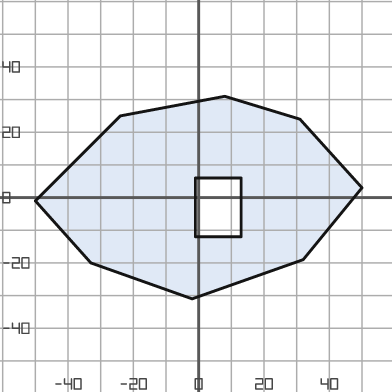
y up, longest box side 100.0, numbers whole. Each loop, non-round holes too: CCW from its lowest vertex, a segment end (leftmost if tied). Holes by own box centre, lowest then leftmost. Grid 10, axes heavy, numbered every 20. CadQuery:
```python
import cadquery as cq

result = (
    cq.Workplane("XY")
    .moveTo(-2.0, -31.0)
    .lineTo(32.0, -19.0)
    .lineTo(50.0, 3.0)
    .lineTo(31.0, 24.0)
    .lineTo(8.0, 31.0)
    .lineTo(-24.0, 25.0)
    .lineTo(-50.0, -1.0)
    .lineTo(-33.0, -20.0)
    .close()
    .moveTo(-1.0, -12.0)
    .lineTo(13.0, -12.0)
    .lineTo(13.0, 6.0)
    .lineTo(-1.0, 6.0)
    .close()
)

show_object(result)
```